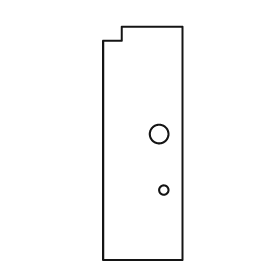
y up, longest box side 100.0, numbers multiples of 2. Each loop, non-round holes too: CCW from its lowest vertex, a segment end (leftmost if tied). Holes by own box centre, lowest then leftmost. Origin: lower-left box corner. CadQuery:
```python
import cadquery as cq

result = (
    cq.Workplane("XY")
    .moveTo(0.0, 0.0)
    .lineTo(34.0, 0.0)
    .lineTo(34.0, 100.0)
    .lineTo(8.0, 100.0)
    .lineTo(8.0, 94.0)
    .lineTo(0.0, 94.0)
    .close()
    .moveTo(26.0, 30.0)
    .circle(2.0)
    .moveTo(24.0, 54.0)
    .circle(4.0)
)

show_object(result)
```